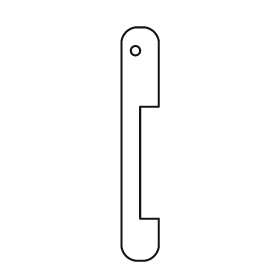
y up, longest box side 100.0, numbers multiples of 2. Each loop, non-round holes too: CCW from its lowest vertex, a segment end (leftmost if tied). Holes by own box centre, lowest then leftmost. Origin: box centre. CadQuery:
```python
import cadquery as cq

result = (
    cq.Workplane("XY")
    .moveTo(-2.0, -50.0)
    .lineTo(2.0, -50.0)
    .threePointArc((6.0, -48.0), (8.0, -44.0))
    .lineTo(8.0, -32.0)
    .lineTo(0.0, -32.0)
    .lineTo(0.0, 16.0)
    .lineTo(8.0, 16.0)
    .lineTo(8.0, 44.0)
    .threePointArc((6.0, 48.0), (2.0, 50.0))
    .lineTo(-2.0, 50.0)
    .threePointArc((-6.0, 48.0), (-8.0, 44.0))
    .lineTo(-8.0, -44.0)
    .threePointArc((-6.0, -48.0), (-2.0, -50.0))
    .close()
    .moveTo(-2.0, 40.0)
    .circle(2.0)
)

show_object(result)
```